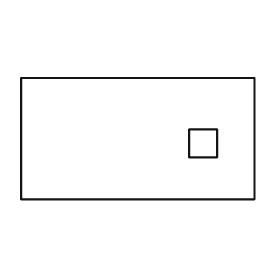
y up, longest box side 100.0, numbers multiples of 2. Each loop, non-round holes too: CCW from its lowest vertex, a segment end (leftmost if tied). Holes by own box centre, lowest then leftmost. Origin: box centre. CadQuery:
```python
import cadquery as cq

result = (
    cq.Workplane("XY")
    .moveTo(-50.0, -26.0)
    .lineTo(50.0, -26.0)
    .lineTo(50.0, 26.0)
    .lineTo(-50.0, 26.0)
    .close()
    .moveTo(22.0, -8.0)
    .lineTo(34.0, -8.0)
    .lineTo(34.0, 4.0)
    .lineTo(22.0, 4.0)
    .close()
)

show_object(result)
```